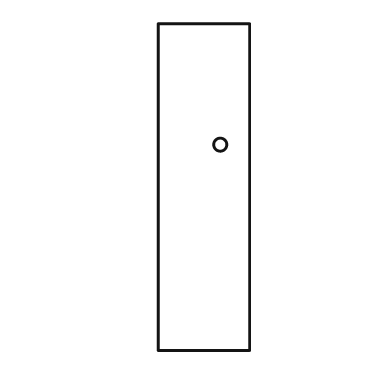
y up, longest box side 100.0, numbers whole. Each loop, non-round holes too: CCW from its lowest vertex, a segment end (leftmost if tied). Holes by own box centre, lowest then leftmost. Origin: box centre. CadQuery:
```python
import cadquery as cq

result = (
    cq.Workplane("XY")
    .moveTo(-14.0, -50.0)
    .lineTo(14.0, -50.0)
    .lineTo(14.0, 50.0)
    .lineTo(-14.0, 50.0)
    .close()
    .moveTo(5.0, 13.0)
    .circle(2.0)
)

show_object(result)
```